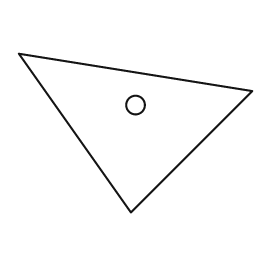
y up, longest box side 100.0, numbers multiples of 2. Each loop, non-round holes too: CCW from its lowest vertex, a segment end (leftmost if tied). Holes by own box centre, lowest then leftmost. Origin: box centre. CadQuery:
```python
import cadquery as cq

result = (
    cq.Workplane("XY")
    .moveTo(-2.0, -34.0)
    .lineTo(50.0, 18.0)
    .lineTo(-50.0, 34.0)
    .close()
    .moveTo(0.0, 12.0)
    .circle(4.0)
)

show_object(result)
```